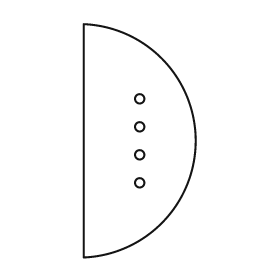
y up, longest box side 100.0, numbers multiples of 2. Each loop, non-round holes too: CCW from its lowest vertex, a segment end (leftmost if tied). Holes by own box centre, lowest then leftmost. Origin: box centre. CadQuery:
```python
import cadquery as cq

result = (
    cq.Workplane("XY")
    .moveTo(-24.0, -50.0)
    .threePointArc((24.0, 0.0), (-24.0, 50.0))
    .close()
    .moveTo(0.0, -18.0)
    .circle(2.0)
    .moveTo(0.0, -6.0)
    .circle(2.0)
    .moveTo(0.0, 6.0)
    .circle(2.0)
    .moveTo(0.0, 18.0)
    .circle(2.0)
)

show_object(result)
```